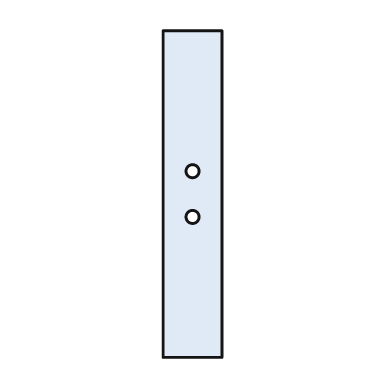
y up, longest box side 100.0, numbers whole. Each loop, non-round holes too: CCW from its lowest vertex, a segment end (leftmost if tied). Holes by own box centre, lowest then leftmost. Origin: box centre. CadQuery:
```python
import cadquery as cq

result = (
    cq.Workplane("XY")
    .moveTo(-9.0, -50.0)
    .lineTo(9.0, -50.0)
    .lineTo(9.0, 50.0)
    .lineTo(-9.0, 50.0)
    .close()
    .moveTo(0.0, -7.0)
    .circle(2.0)
    .moveTo(0.0, 7.0)
    .circle(2.0)
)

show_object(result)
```